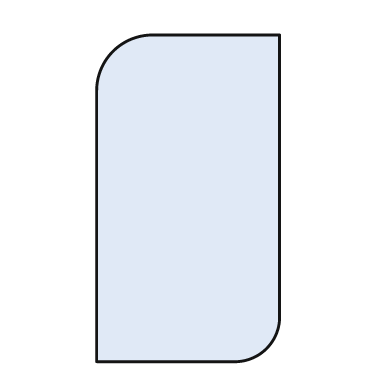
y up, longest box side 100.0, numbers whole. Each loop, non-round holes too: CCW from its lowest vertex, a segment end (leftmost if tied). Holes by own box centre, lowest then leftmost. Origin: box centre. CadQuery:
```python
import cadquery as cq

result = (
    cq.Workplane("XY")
    .moveTo(-28.0, -50.0)
    .lineTo(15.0, -50.0)
    .threePointArc((24.0, -46.0), (28.0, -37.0))
    .lineTo(28.0, 50.0)
    .lineTo(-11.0, 50.0)
    .threePointArc((-23.0, 45.0), (-28.0, 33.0))
    .close()
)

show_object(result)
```